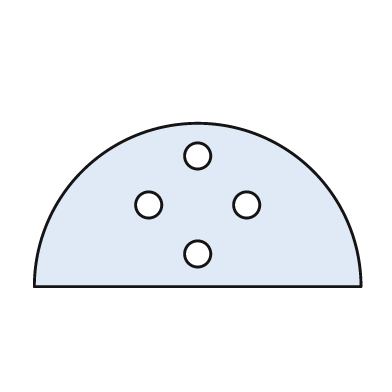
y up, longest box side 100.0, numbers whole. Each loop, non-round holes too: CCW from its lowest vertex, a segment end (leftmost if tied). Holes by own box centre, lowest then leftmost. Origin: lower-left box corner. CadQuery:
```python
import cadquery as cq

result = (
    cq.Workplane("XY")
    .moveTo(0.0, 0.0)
    .lineTo(100.0, 0.0)
    .threePointArc((50.0, 50.0), (0.0, 0.0))
    .close()
    .moveTo(50.0, 10.0)
    .circle(4.0)
    .moveTo(35.0, 25.0)
    .circle(4.0)
    .moveTo(65.0, 25.0)
    .circle(4.0)
    .moveTo(50.0, 40.0)
    .circle(4.0)
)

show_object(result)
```